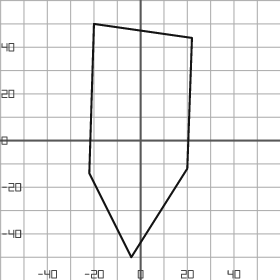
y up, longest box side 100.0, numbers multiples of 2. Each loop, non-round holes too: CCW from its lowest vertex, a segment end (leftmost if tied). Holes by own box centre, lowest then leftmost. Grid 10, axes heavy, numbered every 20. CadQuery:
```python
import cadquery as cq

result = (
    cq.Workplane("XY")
    .moveTo(-4.0, -50.0)
    .lineTo(20.0, -12.0)
    .lineTo(22.0, 44.0)
    .lineTo(-20.0, 50.0)
    .lineTo(-22.0, -14.0)
    .close()
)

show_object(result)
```